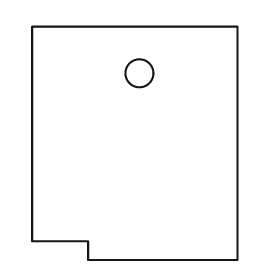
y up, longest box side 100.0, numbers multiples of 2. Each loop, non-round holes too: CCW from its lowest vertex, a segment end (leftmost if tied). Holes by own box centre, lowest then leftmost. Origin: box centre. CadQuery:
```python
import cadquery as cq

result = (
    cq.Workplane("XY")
    .moveTo(-20.0, -50.0)
    .lineTo(44.0, -50.0)
    .lineTo(44.0, 50.0)
    .lineTo(-44.0, 50.0)
    .lineTo(-44.0, -42.0)
    .lineTo(-20.0, -42.0)
    .close()
    .moveTo(2.0, 30.0)
    .circle(6.0)
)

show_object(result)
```